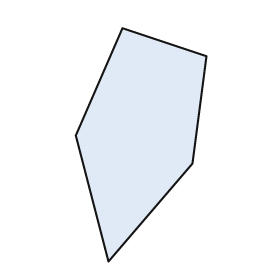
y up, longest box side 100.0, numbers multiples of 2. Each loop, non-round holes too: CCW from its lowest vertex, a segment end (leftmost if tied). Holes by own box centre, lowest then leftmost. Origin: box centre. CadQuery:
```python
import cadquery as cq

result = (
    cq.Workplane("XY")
    .moveTo(-14.0, -50.0)
    .lineTo(22.0, -8.0)
    .lineTo(28.0, 38.0)
    .lineTo(-8.0, 50.0)
    .lineTo(-28.0, 4.0)
    .close()
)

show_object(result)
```